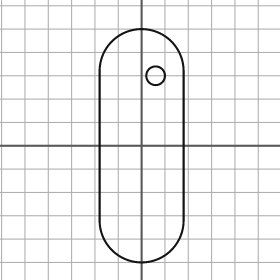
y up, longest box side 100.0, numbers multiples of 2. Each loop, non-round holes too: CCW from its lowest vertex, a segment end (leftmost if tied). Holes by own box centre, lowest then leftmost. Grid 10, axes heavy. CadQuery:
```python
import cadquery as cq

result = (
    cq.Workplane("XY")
    .moveTo(-18.0, -32.0)
    .threePointArc((0.0, -50.0), (18.0, -32.0))
    .lineTo(18.0, 32.0)
    .threePointArc((0.0, 50.0), (-18.0, 32.0))
    .close()
    .moveTo(6.0, 30.0)
    .circle(4.0)
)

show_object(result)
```